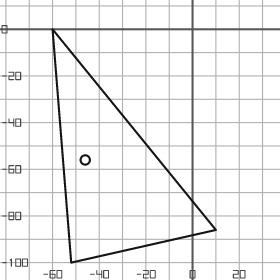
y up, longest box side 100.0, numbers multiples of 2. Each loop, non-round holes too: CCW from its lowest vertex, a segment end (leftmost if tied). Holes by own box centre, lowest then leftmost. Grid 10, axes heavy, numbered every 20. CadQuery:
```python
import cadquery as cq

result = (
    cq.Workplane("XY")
    .moveTo(-52.0, -100.0)
    .lineTo(10.0, -86.0)
    .lineTo(-60.0, 0.0)
    .close()
    .moveTo(-46.0, -56.0)
    .circle(2.0)
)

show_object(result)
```